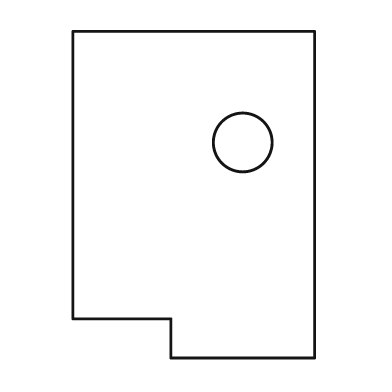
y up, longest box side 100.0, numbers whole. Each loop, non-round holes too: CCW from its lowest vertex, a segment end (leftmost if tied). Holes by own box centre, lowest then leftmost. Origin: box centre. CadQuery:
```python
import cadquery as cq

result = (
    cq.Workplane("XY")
    .moveTo(-7.0, -50.0)
    .lineTo(37.0, -50.0)
    .lineTo(37.0, 50.0)
    .lineTo(-37.0, 50.0)
    .lineTo(-37.0, -38.0)
    .lineTo(-7.0, -38.0)
    .close()
    .moveTo(15.0, 16.0)
    .circle(9.0)
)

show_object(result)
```